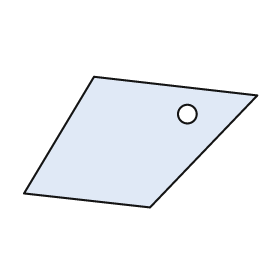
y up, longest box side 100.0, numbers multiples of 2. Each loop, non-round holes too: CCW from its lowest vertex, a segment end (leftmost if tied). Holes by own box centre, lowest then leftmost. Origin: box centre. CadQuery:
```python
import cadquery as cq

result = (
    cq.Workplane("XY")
    .moveTo(4.0, -28.0)
    .lineTo(50.0, 20.0)
    .lineTo(-20.0, 28.0)
    .lineTo(-50.0, -22.0)
    .close()
    .moveTo(20.0, 12.0)
    .circle(4.0)
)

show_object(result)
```